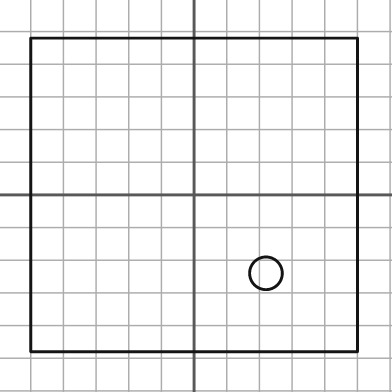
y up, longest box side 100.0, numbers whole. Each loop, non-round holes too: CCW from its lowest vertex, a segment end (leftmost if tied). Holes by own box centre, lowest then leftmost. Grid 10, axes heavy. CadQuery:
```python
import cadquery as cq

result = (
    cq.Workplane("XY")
    .moveTo(-50.0, -48.0)
    .lineTo(50.0, -48.0)
    .lineTo(50.0, 48.0)
    .lineTo(-50.0, 48.0)
    .close()
    .moveTo(22.0, -24.0)
    .circle(5.0)
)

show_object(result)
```